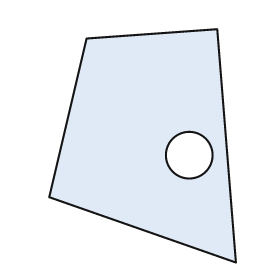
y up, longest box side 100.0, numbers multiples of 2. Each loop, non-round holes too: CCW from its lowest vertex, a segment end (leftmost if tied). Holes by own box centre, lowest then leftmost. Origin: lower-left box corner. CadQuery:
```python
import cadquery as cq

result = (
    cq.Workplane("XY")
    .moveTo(80.0, 0.0)
    .lineTo(72.0, 100.0)
    .lineTo(16.0, 96.0)
    .lineTo(0.0, 28.0)
    .close()
    .moveTo(60.0, 46.0)
    .circle(10.0)
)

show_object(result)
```